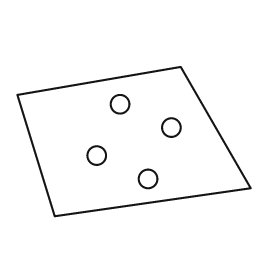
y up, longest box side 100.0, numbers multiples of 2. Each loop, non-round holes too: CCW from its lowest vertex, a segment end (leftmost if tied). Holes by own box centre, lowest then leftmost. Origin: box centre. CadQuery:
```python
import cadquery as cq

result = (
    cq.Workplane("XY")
    .moveTo(-34.0, -32.0)
    .lineTo(50.0, -20.0)
    .lineTo(20.0, 32.0)
    .lineTo(-50.0, 20.0)
    .close()
    .moveTo(6.0, -16.0)
    .circle(4.0)
    .moveTo(-16.0, -6.0)
    .circle(4.0)
    .moveTo(16.0, 6.0)
    .circle(4.0)
    .moveTo(-6.0, 16.0)
    .circle(4.0)
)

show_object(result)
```